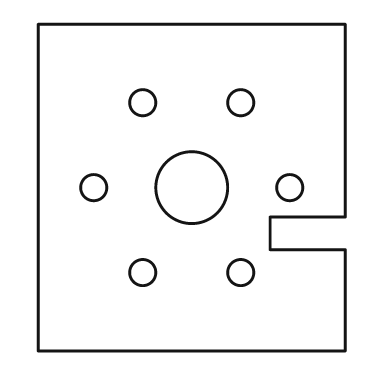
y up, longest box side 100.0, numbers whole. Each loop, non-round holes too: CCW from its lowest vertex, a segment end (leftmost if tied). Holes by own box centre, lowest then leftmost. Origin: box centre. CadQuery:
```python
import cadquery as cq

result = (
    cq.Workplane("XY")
    .moveTo(-47.0, -50.0)
    .lineTo(47.0, -50.0)
    .lineTo(47.0, -19.0)
    .lineTo(24.0, -19.0)
    .lineTo(24.0, -9.0)
    .lineTo(47.0, -9.0)
    .lineTo(47.0, 50.0)
    .lineTo(-47.0, 50.0)
    .close()
    .moveTo(-15.0, -26.0)
    .circle(4.0)
    .moveTo(15.0, -26.0)
    .circle(4.0)
    .moveTo(-30.0, 0.0)
    .circle(4.0)
    .moveTo(0.0, 0.0)
    .circle(11.0)
    .moveTo(30.0, 0.0)
    .circle(4.0)
    .moveTo(-15.0, 26.0)
    .circle(4.0)
    .moveTo(15.0, 26.0)
    .circle(4.0)
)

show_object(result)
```